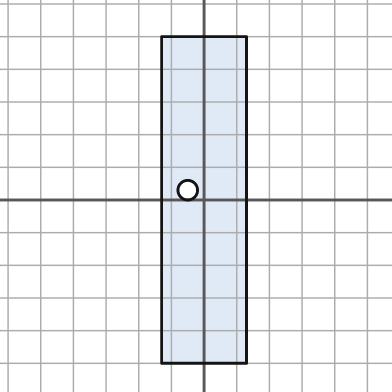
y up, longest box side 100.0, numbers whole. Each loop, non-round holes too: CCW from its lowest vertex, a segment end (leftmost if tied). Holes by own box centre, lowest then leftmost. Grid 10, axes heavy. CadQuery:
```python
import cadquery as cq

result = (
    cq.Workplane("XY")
    .moveTo(-13.0, -50.0)
    .lineTo(13.0, -50.0)
    .lineTo(13.0, 50.0)
    .lineTo(-13.0, 50.0)
    .close()
    .moveTo(-5.0, 3.0)
    .circle(3.0)
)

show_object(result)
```